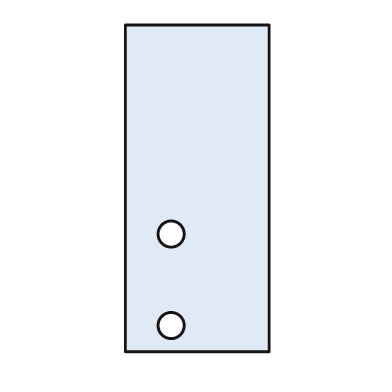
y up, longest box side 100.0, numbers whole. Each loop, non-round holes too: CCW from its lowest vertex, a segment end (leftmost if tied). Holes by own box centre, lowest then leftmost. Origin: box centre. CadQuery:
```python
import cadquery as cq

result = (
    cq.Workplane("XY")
    .moveTo(-22.0, -50.0)
    .lineTo(22.0, -50.0)
    .lineTo(22.0, 50.0)
    .lineTo(-22.0, 50.0)
    .close()
    .moveTo(-8.0, -42.0)
    .circle(4.0)
    .moveTo(-8.0, -14.0)
    .circle(4.0)
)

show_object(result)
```